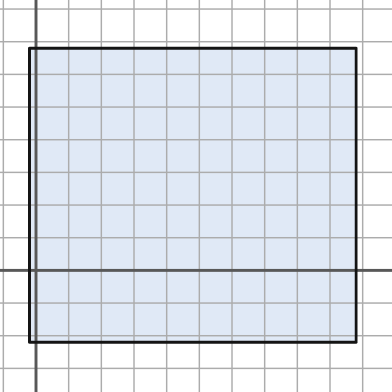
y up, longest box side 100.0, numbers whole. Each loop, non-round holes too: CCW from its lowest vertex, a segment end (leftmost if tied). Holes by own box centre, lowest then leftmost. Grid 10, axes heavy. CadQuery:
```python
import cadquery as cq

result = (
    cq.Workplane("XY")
    .moveTo(-2.0, -22.0)
    .lineTo(98.0, -22.0)
    .lineTo(98.0, 68.0)
    .lineTo(-2.0, 68.0)
    .close()
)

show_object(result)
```